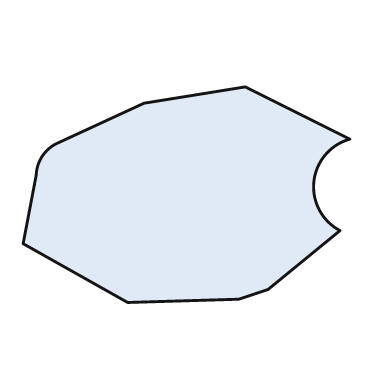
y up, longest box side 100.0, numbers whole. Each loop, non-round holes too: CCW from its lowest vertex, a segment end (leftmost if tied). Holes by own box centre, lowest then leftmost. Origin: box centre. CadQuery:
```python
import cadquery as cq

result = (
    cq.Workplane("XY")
    .moveTo(-18.0, -33.0)
    .lineTo(16.0, -32.0)
    .lineTo(25.0, -29.0)
    .lineTo(47.0, -11.0)
    .threePointArc((39.0, 4.0), (50.0, 17.0))
    .lineTo(18.0, 33.0)
    .lineTo(-13.0, 28.0)
    .lineTo(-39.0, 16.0)
    .threePointArc((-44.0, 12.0), (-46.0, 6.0))
    .lineTo(-50.0, -15.0)
    .close()
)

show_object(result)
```